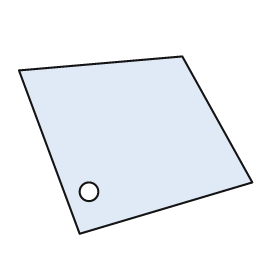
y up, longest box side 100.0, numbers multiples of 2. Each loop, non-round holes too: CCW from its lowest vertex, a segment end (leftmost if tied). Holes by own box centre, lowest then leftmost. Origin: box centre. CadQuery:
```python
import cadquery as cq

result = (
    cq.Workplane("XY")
    .moveTo(-24.0, -38.0)
    .lineTo(50.0, -16.0)
    .lineTo(20.0, 38.0)
    .lineTo(-50.0, 32.0)
    .close()
    .moveTo(-20.0, -20.0)
    .circle(4.0)
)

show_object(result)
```